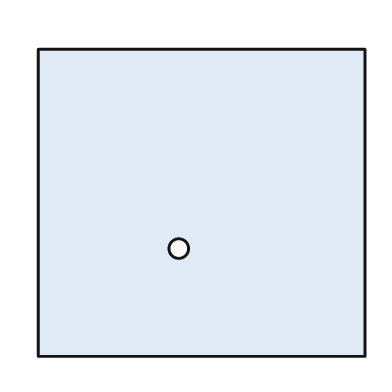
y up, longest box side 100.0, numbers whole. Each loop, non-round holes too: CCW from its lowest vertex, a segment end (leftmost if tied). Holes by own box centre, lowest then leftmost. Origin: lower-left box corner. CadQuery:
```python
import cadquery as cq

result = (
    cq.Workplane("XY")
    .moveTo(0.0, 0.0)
    .lineTo(100.0, 0.0)
    .lineTo(100.0, 94.0)
    .lineTo(0.0, 94.0)
    .close()
    .moveTo(43.0, 33.0)
    .circle(3.0)
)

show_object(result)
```